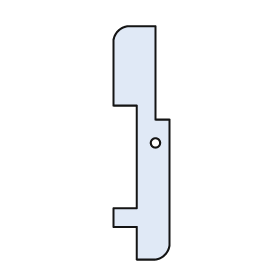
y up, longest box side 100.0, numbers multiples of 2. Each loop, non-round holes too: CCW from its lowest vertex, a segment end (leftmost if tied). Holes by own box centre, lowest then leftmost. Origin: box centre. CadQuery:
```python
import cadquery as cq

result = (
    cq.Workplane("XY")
    .moveTo(-2.0, -50.0)
    .lineTo(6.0, -50.0)
    .threePointArc((10.0, -48.0), (12.0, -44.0))
    .lineTo(12.0, 10.0)
    .lineTo(6.0, 10.0)
    .lineTo(6.0, 50.0)
    .lineTo(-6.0, 50.0)
    .threePointArc((-10.0, 48.0), (-12.0, 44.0))
    .lineTo(-12.0, 16.0)
    .lineTo(-2.0, 16.0)
    .lineTo(-2.0, -28.0)
    .lineTo(-12.0, -28.0)
    .lineTo(-12.0, -36.0)
    .lineTo(-2.0, -36.0)
    .close()
    .moveTo(6.0, 0.0)
    .circle(2.0)
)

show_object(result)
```